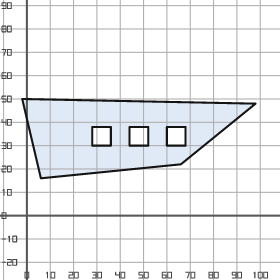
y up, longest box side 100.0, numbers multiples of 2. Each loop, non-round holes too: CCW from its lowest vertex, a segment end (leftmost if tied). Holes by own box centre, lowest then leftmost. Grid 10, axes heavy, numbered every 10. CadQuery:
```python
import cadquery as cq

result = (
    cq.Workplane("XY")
    .moveTo(6.0, 16.0)
    .lineTo(66.0, 22.0)
    .lineTo(98.0, 48.0)
    .lineTo(-2.0, 50.0)
    .close()
    .moveTo(28.0, 30.0)
    .lineTo(36.0, 30.0)
    .lineTo(36.0, 38.0)
    .lineTo(28.0, 38.0)
    .close()
    .moveTo(44.0, 30.0)
    .lineTo(52.0, 30.0)
    .lineTo(52.0, 38.0)
    .lineTo(44.0, 38.0)
    .close()
    .moveTo(60.0, 30.0)
    .lineTo(68.0, 30.0)
    .lineTo(68.0, 38.0)
    .lineTo(60.0, 38.0)
    .close()
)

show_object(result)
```